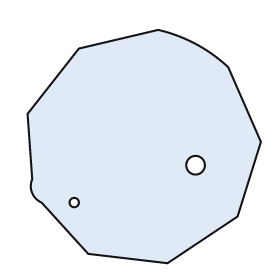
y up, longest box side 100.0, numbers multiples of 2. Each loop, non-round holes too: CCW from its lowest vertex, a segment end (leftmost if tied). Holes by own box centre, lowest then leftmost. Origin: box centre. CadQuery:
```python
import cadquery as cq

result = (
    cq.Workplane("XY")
    .moveTo(10.0, -50.0)
    .lineTo(40.0, -30.0)
    .lineTo(50.0, 2.0)
    .lineTo(36.0, 34.0)
    .threePointArc((22.0, 44.0), (6.0, 50.0))
    .lineTo(-28.0, 42.0)
    .lineTo(-50.0, 14.0)
    .lineTo(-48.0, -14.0)
    .threePointArc((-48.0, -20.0), (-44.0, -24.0))
    .lineTo(-24.0, -46.0)
    .close()
    .moveTo(-30.0, -24.0)
    .circle(2.0)
    .moveTo(22.0, -8.0)
    .circle(4.0)
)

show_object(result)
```